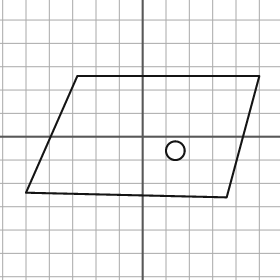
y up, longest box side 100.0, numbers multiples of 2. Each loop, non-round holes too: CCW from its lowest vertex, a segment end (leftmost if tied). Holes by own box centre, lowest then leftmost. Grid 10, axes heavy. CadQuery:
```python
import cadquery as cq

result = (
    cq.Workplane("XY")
    .moveTo(36.0, -26.0)
    .lineTo(50.0, 26.0)
    .lineTo(-28.0, 26.0)
    .lineTo(-50.0, -24.0)
    .close()
    .moveTo(14.0, -6.0)
    .circle(4.0)
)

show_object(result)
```